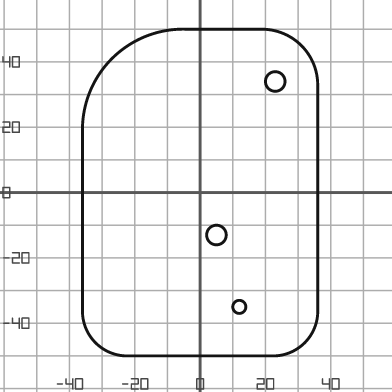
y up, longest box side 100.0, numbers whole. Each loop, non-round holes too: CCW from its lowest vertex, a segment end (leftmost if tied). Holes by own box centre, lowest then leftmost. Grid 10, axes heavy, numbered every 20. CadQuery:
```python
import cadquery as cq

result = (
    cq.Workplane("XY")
    .moveTo(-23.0, -50.0)
    .lineTo(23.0, -50.0)
    .threePointArc((32.0, -46.0), (36.0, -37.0))
    .lineTo(36.0, 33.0)
    .threePointArc((31.0, 45.0), (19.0, 50.0))
    .lineTo(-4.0, 50.0)
    .threePointArc((-27.0, 41.0), (-36.0, 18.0))
    .lineTo(-36.0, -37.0)
    .threePointArc((-32.0, -46.0), (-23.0, -50.0))
    .close()
    .moveTo(12.0, -35.0)
    .circle(2.0)
    .moveTo(5.0, -13.0)
    .circle(3.0)
    .moveTo(23.0, 34.0)
    .circle(3.0)
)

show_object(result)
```